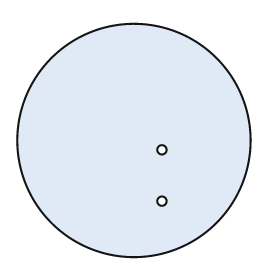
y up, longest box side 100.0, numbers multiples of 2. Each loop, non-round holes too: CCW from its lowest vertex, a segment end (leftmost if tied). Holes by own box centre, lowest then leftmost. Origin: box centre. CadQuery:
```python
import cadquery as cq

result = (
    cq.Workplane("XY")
    .moveTo(0.0, 0.0)
    .circle(50.0)
    .moveTo(12.0, -26.0)
    .circle(2.0)
    .moveTo(12.0, -4.0)
    .circle(2.0)
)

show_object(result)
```